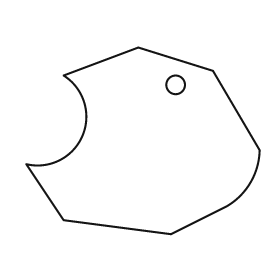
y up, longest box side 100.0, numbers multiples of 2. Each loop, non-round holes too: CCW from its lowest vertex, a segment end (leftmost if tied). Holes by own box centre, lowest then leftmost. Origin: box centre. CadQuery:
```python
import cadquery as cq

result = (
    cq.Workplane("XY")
    .moveTo(12.0, -40.0)
    .lineTo(36.0, -28.0)
    .threePointArc((46.0, -18.0), (50.0, -4.0))
    .lineTo(30.0, 30.0)
    .lineTo(-2.0, 40.0)
    .lineTo(-34.0, 28.0)
    .threePointArc((-26.0, 2.0), (-50.0, -10.0))
    .lineTo(-34.0, -34.0)
    .close()
    .moveTo(14.0, 24.0)
    .circle(4.0)
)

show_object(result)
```